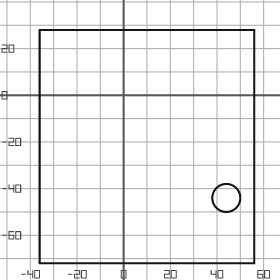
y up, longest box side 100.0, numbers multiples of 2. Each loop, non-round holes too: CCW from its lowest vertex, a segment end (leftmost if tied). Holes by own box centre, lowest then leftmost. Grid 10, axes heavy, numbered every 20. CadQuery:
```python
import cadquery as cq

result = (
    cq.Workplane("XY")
    .moveTo(-36.0, -72.0)
    .lineTo(56.0, -72.0)
    .lineTo(56.0, 28.0)
    .lineTo(-36.0, 28.0)
    .close()
    .moveTo(44.0, -44.0)
    .circle(6.0)
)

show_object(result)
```